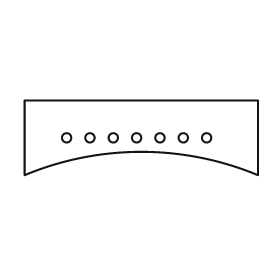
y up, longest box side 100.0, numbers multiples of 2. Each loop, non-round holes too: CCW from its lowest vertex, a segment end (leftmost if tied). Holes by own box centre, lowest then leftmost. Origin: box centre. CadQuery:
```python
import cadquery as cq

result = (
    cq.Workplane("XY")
    .moveTo(-50.0, -16.0)
    .threePointArc((0.0, -6.0), (50.0, -16.0))
    .lineTo(50.0, 16.0)
    .lineTo(-50.0, 16.0)
    .close()
    .moveTo(-32.0, 0.0)
    .circle(2.0)
    .moveTo(-22.0, 0.0)
    .circle(2.0)
    .moveTo(-12.0, 0.0)
    .circle(2.0)
    .moveTo(-2.0, 0.0)
    .circle(2.0)
    .moveTo(8.0, 0.0)
    .circle(2.0)
    .moveTo(18.0, 0.0)
    .circle(2.0)
    .moveTo(28.0, 0.0)
    .circle(2.0)
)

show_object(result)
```